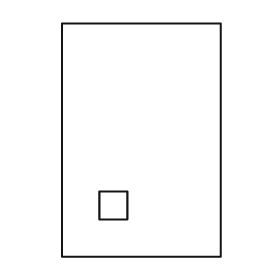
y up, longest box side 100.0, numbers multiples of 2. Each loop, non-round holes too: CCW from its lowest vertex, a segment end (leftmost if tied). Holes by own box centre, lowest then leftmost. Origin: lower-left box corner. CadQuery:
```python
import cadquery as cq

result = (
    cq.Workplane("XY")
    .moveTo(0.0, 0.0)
    .lineTo(68.0, 0.0)
    .lineTo(68.0, 100.0)
    .lineTo(0.0, 100.0)
    .close()
    .moveTo(16.0, 16.0)
    .lineTo(28.0, 16.0)
    .lineTo(28.0, 28.0)
    .lineTo(16.0, 28.0)
    .close()
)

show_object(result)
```